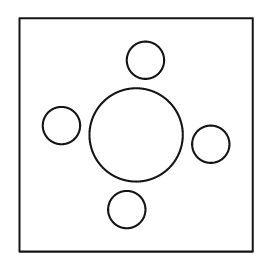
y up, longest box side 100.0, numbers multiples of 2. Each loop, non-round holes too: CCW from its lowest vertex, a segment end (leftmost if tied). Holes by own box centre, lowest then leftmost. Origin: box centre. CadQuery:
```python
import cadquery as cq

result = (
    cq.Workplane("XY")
    .moveTo(-50.0, -50.0)
    .lineTo(50.0, -50.0)
    .lineTo(50.0, 50.0)
    .lineTo(-50.0, 50.0)
    .close()
    .moveTo(-4.0, -32.0)
    .circle(8.0)
    .moveTo(32.0, -4.0)
    .circle(8.0)
    .moveTo(0.0, 0.0)
    .circle(20.0)
    .moveTo(-32.0, 4.0)
    .circle(8.0)
    .moveTo(4.0, 32.0)
    .circle(8.0)
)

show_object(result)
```